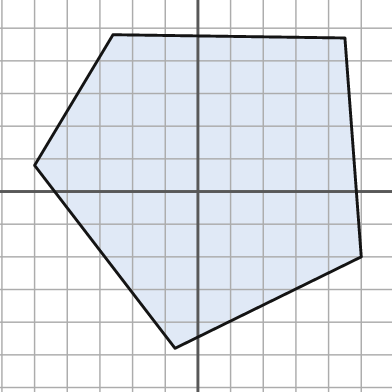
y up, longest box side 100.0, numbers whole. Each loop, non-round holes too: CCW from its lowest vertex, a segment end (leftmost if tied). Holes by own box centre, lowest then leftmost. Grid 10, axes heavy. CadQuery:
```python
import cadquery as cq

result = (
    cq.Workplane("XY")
    .moveTo(-7.0, -48.0)
    .lineTo(50.0, -20.0)
    .lineTo(45.0, 47.0)
    .lineTo(-26.0, 48.0)
    .lineTo(-50.0, 8.0)
    .close()
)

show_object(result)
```